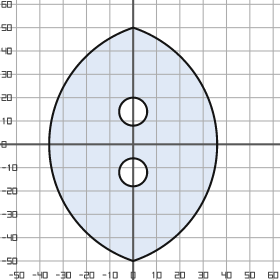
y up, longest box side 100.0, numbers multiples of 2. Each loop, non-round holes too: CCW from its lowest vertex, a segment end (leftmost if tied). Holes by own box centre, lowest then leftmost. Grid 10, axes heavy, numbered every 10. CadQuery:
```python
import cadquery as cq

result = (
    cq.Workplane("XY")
    .moveTo(0.0, -50.0)
    .threePointArc((36.0, 0.0), (0.0, 50.0))
    .threePointArc((-36.0, 0.0), (0.0, -50.0))
    .close()
    .moveTo(0.0, -12.0)
    .circle(6.0)
    .moveTo(0.0, 14.0)
    .circle(6.0)
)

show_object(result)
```